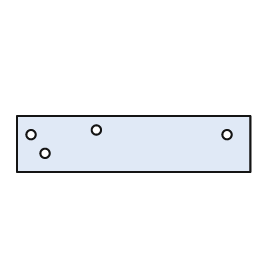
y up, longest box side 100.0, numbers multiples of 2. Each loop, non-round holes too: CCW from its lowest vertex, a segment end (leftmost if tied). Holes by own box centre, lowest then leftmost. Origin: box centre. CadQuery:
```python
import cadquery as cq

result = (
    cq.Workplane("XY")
    .moveTo(-50.0, -12.0)
    .lineTo(50.0, -12.0)
    .lineTo(50.0, 12.0)
    .lineTo(-50.0, 12.0)
    .close()
    .moveTo(-38.0, -4.0)
    .circle(2.0)
    .moveTo(-44.0, 4.0)
    .circle(2.0)
    .moveTo(40.0, 4.0)
    .circle(2.0)
    .moveTo(-16.0, 6.0)
    .circle(2.0)
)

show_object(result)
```